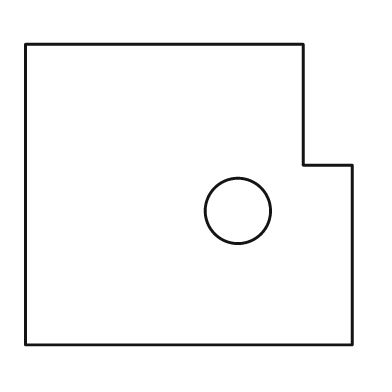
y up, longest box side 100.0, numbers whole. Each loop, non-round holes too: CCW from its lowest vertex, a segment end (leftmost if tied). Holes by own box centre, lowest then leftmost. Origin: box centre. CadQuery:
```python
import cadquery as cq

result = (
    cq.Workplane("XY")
    .moveTo(-50.0, -46.0)
    .lineTo(50.0, -46.0)
    .lineTo(50.0, 9.0)
    .lineTo(35.0, 9.0)
    .lineTo(35.0, 46.0)
    .lineTo(-50.0, 46.0)
    .close()
    .moveTo(15.0, -5.0)
    .circle(10.0)
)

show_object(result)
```